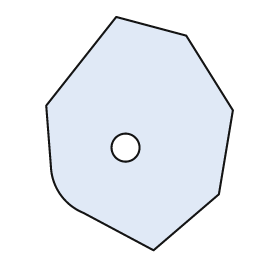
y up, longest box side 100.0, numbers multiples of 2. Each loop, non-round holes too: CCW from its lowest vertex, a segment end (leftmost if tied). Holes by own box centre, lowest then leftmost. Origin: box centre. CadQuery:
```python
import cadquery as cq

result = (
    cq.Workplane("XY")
    .moveTo(6.0, -50.0)
    .lineTo(34.0, -26.0)
    .lineTo(40.0, 10.0)
    .lineTo(20.0, 42.0)
    .lineTo(-10.0, 50.0)
    .lineTo(-40.0, 12.0)
    .lineTo(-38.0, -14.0)
    .threePointArc((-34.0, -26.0), (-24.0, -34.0))
    .close()
    .moveTo(-6.0, -6.0)
    .circle(6.0)
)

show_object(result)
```